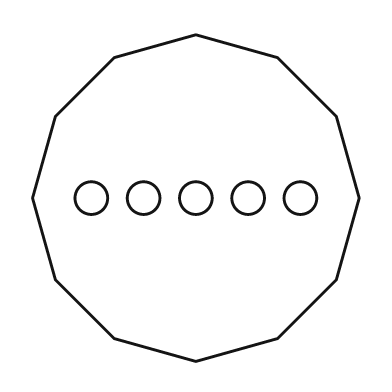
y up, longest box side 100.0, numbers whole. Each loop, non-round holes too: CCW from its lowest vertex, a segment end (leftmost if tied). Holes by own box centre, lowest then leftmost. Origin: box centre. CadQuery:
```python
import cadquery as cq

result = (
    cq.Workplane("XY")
    .moveTo(0.0, -50.0)
    .lineTo(25.0, -43.0)
    .lineTo(43.0, -25.0)
    .lineTo(50.0, 0.0)
    .lineTo(43.0, 25.0)
    .lineTo(25.0, 43.0)
    .lineTo(0.0, 50.0)
    .lineTo(-25.0, 43.0)
    .lineTo(-43.0, 25.0)
    .lineTo(-50.0, 0.0)
    .lineTo(-43.0, -25.0)
    .lineTo(-25.0, -43.0)
    .close()
    .moveTo(-32.0, 0.0)
    .circle(5.0)
    .moveTo(-16.0, 0.0)
    .circle(5.0)
    .moveTo(0.0, 0.0)
    .circle(5.0)
    .moveTo(16.0, 0.0)
    .circle(5.0)
    .moveTo(32.0, 0.0)
    .circle(5.0)
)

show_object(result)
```